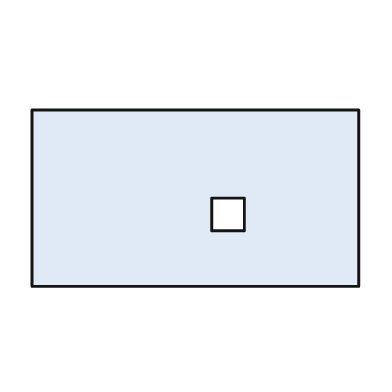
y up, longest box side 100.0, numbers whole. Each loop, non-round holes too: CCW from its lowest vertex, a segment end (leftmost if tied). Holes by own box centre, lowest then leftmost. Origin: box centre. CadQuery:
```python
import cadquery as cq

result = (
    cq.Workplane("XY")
    .moveTo(-50.0, -27.0)
    .lineTo(50.0, -27.0)
    .lineTo(50.0, 27.0)
    .lineTo(-50.0, 27.0)
    .close()
    .moveTo(5.0, -10.0)
    .lineTo(15.0, -10.0)
    .lineTo(15.0, 0.0)
    .lineTo(5.0, 0.0)
    .close()
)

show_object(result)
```